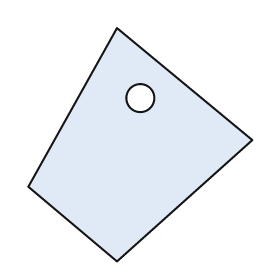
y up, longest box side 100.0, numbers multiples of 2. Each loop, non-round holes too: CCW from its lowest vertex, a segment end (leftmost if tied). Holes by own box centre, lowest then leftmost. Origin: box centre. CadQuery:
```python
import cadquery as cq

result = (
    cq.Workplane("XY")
    .moveTo(-10.0, -50.0)
    .lineTo(48.0, 2.0)
    .lineTo(-10.0, 50.0)
    .lineTo(-48.0, -18.0)
    .close()
    .moveTo(0.0, 20.0)
    .circle(6.0)
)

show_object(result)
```